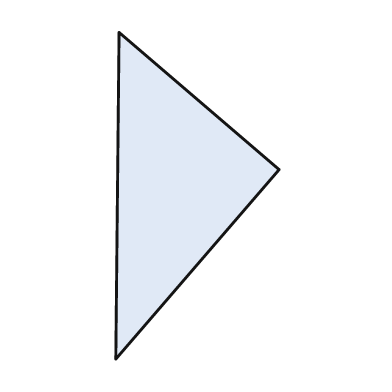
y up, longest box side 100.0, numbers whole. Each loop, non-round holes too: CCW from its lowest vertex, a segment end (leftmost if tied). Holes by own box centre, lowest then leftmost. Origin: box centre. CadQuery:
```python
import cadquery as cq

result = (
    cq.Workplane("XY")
    .moveTo(-25.0, -50.0)
    .lineTo(25.0, 8.0)
    .lineTo(-24.0, 50.0)
    .close()
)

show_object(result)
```